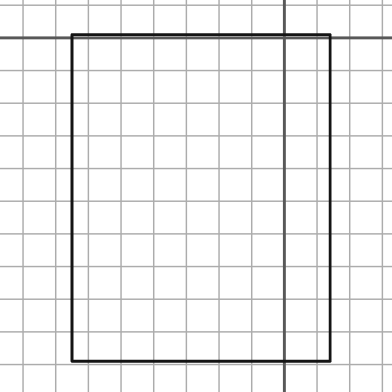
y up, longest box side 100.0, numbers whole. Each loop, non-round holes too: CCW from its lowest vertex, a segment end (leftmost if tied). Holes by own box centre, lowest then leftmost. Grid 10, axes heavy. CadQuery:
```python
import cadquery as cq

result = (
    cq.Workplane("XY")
    .moveTo(-65.0, -99.0)
    .lineTo(14.0, -99.0)
    .lineTo(14.0, 1.0)
    .lineTo(-65.0, 1.0)
    .close()
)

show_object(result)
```